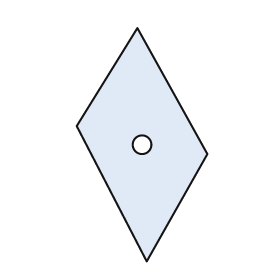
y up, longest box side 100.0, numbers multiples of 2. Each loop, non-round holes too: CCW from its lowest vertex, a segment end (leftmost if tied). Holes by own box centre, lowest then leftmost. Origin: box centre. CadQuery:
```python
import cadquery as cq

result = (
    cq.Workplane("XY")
    .moveTo(2.0, -50.0)
    .lineTo(28.0, -4.0)
    .lineTo(-2.0, 50.0)
    .lineTo(-28.0, 8.0)
    .close()
    .moveTo(0.0, 0.0)
    .circle(4.0)
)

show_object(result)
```